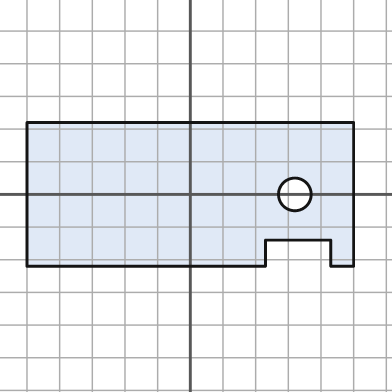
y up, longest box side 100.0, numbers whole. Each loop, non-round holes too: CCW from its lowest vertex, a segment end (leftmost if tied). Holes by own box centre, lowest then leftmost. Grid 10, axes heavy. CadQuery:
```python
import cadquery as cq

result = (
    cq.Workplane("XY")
    .moveTo(-50.0, -22.0)
    .lineTo(23.0, -22.0)
    .lineTo(23.0, -14.0)
    .lineTo(43.0, -14.0)
    .lineTo(43.0, -22.0)
    .lineTo(50.0, -22.0)
    .lineTo(50.0, 22.0)
    .lineTo(-50.0, 22.0)
    .close()
    .moveTo(32.0, 0.0)
    .circle(5.0)
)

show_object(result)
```